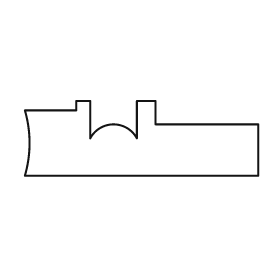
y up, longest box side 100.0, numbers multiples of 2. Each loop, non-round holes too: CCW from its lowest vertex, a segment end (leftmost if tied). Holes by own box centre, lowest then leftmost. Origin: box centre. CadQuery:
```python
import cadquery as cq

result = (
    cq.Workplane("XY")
    .moveTo(-50.0, -16.0)
    .lineTo(50.0, -16.0)
    .lineTo(50.0, 6.0)
    .lineTo(6.0, 6.0)
    .lineTo(6.0, 16.0)
    .lineTo(-2.0, 16.0)
    .lineTo(-2.0, 0.0)
    .threePointArc((-12.0, 6.0), (-22.0, 0.0))
    .lineTo(-22.0, 16.0)
    .lineTo(-28.0, 16.0)
    .lineTo(-28.0, 12.0)
    .lineTo(-50.0, 12.0)
    .threePointArc((-48.0, -2.0), (-50.0, -16.0))
    .close()
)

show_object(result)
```